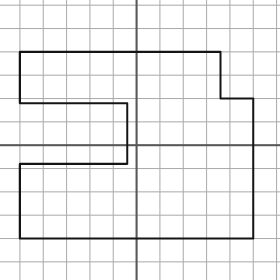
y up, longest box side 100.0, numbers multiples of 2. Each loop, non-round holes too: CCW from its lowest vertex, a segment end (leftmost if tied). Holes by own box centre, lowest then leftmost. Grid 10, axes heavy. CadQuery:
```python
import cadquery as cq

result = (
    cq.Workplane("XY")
    .moveTo(-50.0, -40.0)
    .lineTo(50.0, -40.0)
    .lineTo(50.0, 20.0)
    .lineTo(36.0, 20.0)
    .lineTo(36.0, 40.0)
    .lineTo(-50.0, 40.0)
    .lineTo(-50.0, 18.0)
    .lineTo(-4.0, 18.0)
    .lineTo(-4.0, -8.0)
    .lineTo(-50.0, -8.0)
    .close()
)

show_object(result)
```